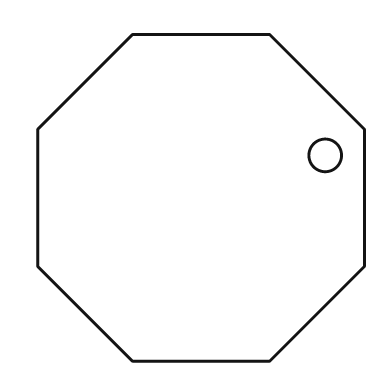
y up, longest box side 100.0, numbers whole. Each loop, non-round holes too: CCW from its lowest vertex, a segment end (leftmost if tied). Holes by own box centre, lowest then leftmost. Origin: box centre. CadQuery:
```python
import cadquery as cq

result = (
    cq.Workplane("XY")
    .moveTo(-21.0, -50.0)
    .lineTo(21.0, -50.0)
    .lineTo(50.0, -21.0)
    .lineTo(50.0, 21.0)
    .lineTo(21.0, 50.0)
    .lineTo(-21.0, 50.0)
    .lineTo(-50.0, 21.0)
    .lineTo(-50.0, -21.0)
    .close()
    .moveTo(38.0, 13.0)
    .circle(5.0)
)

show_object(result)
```